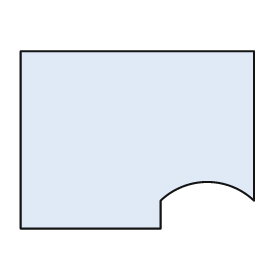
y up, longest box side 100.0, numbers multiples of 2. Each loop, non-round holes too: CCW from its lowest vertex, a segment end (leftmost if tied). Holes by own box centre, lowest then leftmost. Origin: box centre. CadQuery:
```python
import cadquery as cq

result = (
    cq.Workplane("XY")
    .moveTo(-50.0, -38.0)
    .lineTo(10.0, -38.0)
    .lineTo(10.0, -26.0)
    .threePointArc((30.0, -18.0), (50.0, -26.0))
    .lineTo(50.0, 38.0)
    .lineTo(-50.0, 38.0)
    .close()
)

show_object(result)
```